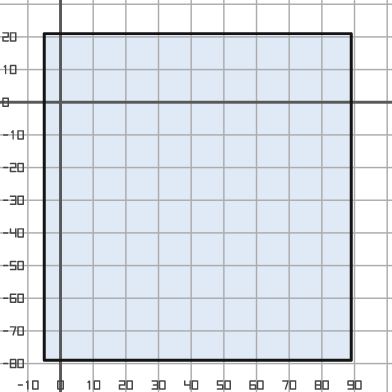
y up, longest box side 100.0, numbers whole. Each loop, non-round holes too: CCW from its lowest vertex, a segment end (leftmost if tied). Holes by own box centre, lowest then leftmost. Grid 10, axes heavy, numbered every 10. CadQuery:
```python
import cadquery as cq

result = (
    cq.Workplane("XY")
    .moveTo(-5.0, -79.0)
    .lineTo(89.0, -79.0)
    .lineTo(89.0, 21.0)
    .lineTo(-5.0, 21.0)
    .close()
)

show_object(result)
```